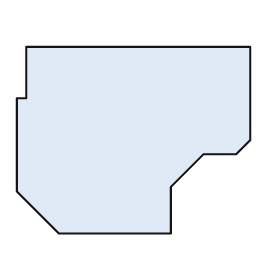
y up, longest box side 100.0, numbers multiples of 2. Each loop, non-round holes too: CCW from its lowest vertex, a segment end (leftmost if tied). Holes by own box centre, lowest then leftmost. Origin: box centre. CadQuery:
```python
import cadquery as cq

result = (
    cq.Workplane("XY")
    .moveTo(-32.0, -40.0)
    .lineTo(16.0, -40.0)
    .lineTo(16.0, -20.0)
    .lineTo(30.0, -6.0)
    .lineTo(44.0, -6.0)
    .lineTo(50.0, 0.0)
    .lineTo(50.0, 40.0)
    .lineTo(-46.0, 40.0)
    .lineTo(-46.0, 18.0)
    .lineTo(-50.0, 18.0)
    .lineTo(-50.0, -22.0)
    .close()
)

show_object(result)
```